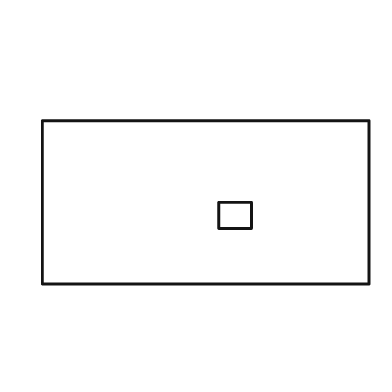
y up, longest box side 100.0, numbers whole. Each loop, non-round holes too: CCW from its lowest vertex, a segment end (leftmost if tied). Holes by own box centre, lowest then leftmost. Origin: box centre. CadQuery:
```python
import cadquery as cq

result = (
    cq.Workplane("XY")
    .moveTo(-50.0, -25.0)
    .lineTo(50.0, -25.0)
    .lineTo(50.0, 25.0)
    .lineTo(-50.0, 25.0)
    .close()
    .moveTo(4.0, -8.0)
    .lineTo(14.0, -8.0)
    .lineTo(14.0, 0.0)
    .lineTo(4.0, 0.0)
    .close()
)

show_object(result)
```